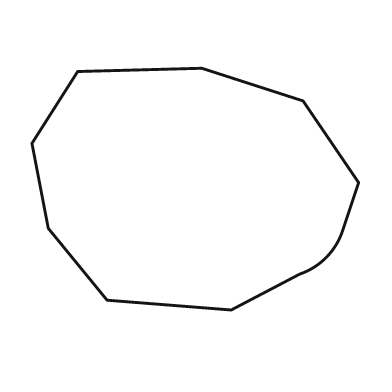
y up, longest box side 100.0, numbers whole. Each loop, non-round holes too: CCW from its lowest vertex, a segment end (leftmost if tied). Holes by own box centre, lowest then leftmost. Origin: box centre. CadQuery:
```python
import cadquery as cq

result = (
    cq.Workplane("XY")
    .moveTo(11.0, -37.0)
    .lineTo(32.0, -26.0)
    .threePointArc((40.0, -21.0), (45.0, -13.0))
    .lineTo(50.0, 2.0)
    .lineTo(33.0, 27.0)
    .lineTo(2.0, 37.0)
    .lineTo(-36.0, 36.0)
    .lineTo(-50.0, 14.0)
    .lineTo(-45.0, -12.0)
    .lineTo(-27.0, -34.0)
    .close()
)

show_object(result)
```